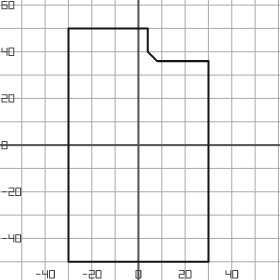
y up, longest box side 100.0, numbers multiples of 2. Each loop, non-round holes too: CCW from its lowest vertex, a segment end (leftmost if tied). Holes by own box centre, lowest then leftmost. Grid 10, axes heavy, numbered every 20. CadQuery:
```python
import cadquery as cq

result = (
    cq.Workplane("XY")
    .moveTo(-30.0, -50.0)
    .lineTo(30.0, -50.0)
    .lineTo(30.0, 36.0)
    .lineTo(8.0, 36.0)
    .lineTo(4.0, 40.0)
    .lineTo(4.0, 50.0)
    .lineTo(-30.0, 50.0)
    .close()
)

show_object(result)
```